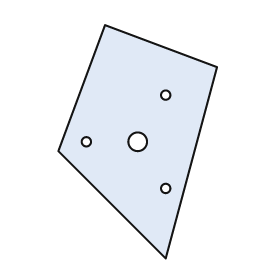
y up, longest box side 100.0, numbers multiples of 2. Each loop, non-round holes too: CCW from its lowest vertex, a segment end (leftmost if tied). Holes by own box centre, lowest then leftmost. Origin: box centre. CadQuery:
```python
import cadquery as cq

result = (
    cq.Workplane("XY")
    .moveTo(12.0, -50.0)
    .lineTo(34.0, 32.0)
    .lineTo(-14.0, 50.0)
    .lineTo(-34.0, -4.0)
    .close()
    .moveTo(12.0, -20.0)
    .circle(2.0)
    .moveTo(-22.0, 0.0)
    .circle(2.0)
    .moveTo(0.0, 0.0)
    .circle(4.0)
    .moveTo(12.0, 20.0)
    .circle(2.0)
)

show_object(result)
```